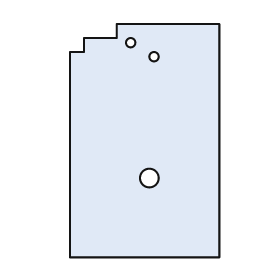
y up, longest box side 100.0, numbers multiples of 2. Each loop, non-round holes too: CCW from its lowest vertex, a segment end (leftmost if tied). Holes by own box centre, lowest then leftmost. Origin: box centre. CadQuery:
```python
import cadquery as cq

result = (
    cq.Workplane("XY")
    .moveTo(-32.0, -50.0)
    .lineTo(32.0, -50.0)
    .lineTo(32.0, 50.0)
    .lineTo(-12.0, 50.0)
    .lineTo(-12.0, 44.0)
    .lineTo(-26.0, 44.0)
    .lineTo(-26.0, 38.0)
    .lineTo(-32.0, 38.0)
    .close()
    .moveTo(2.0, -16.0)
    .circle(4.0)
    .moveTo(4.0, 36.0)
    .circle(2.0)
    .moveTo(-6.0, 42.0)
    .circle(2.0)
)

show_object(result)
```